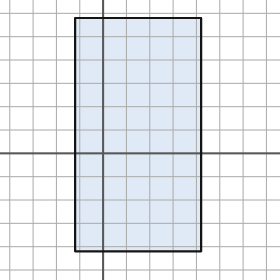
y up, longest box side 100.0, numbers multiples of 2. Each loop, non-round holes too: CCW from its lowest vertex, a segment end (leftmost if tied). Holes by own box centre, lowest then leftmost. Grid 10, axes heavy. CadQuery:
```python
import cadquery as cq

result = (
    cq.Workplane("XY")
    .moveTo(-12.0, -42.0)
    .lineTo(42.0, -42.0)
    .lineTo(42.0, 58.0)
    .lineTo(-12.0, 58.0)
    .close()
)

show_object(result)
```